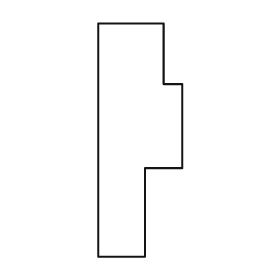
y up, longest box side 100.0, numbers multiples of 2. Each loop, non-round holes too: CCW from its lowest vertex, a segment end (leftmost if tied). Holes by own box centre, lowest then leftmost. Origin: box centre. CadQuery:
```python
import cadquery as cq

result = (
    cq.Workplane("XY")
    .moveTo(-18.0, -50.0)
    .lineTo(2.0, -50.0)
    .lineTo(2.0, -12.0)
    .lineTo(18.0, -12.0)
    .lineTo(18.0, 24.0)
    .lineTo(10.0, 24.0)
    .lineTo(10.0, 50.0)
    .lineTo(-18.0, 50.0)
    .close()
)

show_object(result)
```